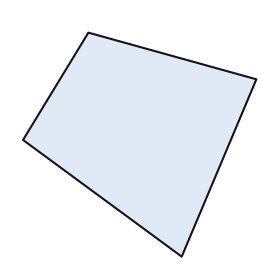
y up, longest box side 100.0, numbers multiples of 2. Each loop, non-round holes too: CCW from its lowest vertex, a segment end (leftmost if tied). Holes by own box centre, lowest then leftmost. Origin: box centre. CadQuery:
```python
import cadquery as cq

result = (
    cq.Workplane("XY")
    .moveTo(18.0, -48.0)
    .lineTo(50.0, 28.0)
    .lineTo(-22.0, 48.0)
    .lineTo(-50.0, 2.0)
    .close()
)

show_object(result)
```